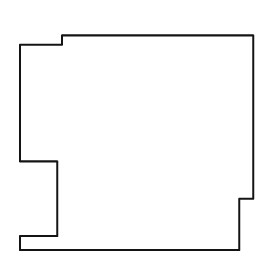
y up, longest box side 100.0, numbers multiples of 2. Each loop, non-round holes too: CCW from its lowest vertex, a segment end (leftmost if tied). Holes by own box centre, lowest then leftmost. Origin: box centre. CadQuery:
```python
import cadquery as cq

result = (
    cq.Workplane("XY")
    .moveTo(-50.0, -46.0)
    .lineTo(44.0, -46.0)
    .lineTo(44.0, -24.0)
    .lineTo(50.0, -24.0)
    .lineTo(50.0, 46.0)
    .lineTo(-32.0, 46.0)
    .lineTo(-32.0, 42.0)
    .lineTo(-50.0, 42.0)
    .lineTo(-50.0, -8.0)
    .lineTo(-34.0, -8.0)
    .lineTo(-34.0, -40.0)
    .lineTo(-50.0, -40.0)
    .close()
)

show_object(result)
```